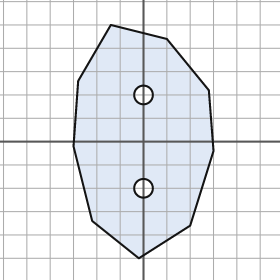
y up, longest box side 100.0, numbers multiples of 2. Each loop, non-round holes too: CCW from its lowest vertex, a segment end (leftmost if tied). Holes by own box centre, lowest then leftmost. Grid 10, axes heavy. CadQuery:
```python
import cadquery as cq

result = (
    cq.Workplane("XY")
    .moveTo(-2.0, -50.0)
    .lineTo(20.0, -36.0)
    .lineTo(30.0, -4.0)
    .lineTo(28.0, 22.0)
    .lineTo(10.0, 44.0)
    .lineTo(-14.0, 50.0)
    .lineTo(-28.0, 26.0)
    .lineTo(-30.0, -2.0)
    .lineTo(-22.0, -34.0)
    .close()
    .moveTo(0.0, -20.0)
    .circle(4.0)
    .moveTo(0.0, 20.0)
    .circle(4.0)
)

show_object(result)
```